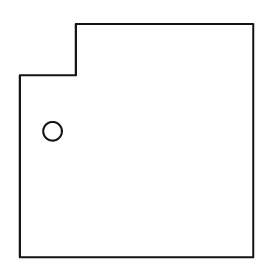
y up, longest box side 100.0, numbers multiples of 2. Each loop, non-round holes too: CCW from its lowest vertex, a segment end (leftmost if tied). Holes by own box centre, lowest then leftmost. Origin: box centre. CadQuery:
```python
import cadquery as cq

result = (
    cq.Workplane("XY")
    .moveTo(-50.0, -50.0)
    .lineTo(50.0, -50.0)
    .lineTo(50.0, 50.0)
    .lineTo(-26.0, 50.0)
    .lineTo(-26.0, 28.0)
    .lineTo(-50.0, 28.0)
    .close()
    .moveTo(-36.0, 4.0)
    .circle(4.0)
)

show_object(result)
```